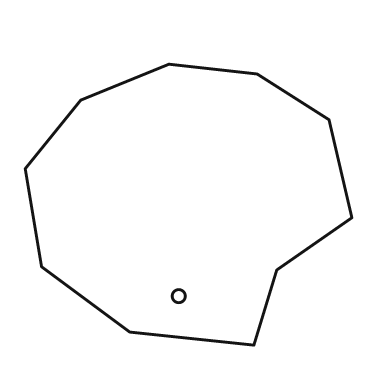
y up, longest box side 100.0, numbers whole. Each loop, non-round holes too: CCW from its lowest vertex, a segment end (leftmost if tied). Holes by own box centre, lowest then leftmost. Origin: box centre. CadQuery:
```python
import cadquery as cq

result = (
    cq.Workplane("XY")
    .moveTo(20.0, -43.0)
    .lineTo(27.0, -20.0)
    .lineTo(50.0, -4.0)
    .lineTo(43.0, 26.0)
    .lineTo(21.0, 40.0)
    .lineTo(-6.0, 43.0)
    .lineTo(-33.0, 32.0)
    .lineTo(-50.0, 11.0)
    .lineTo(-45.0, -19.0)
    .lineTo(-18.0, -39.0)
    .close()
    .moveTo(-3.0, -28.0)
    .circle(2.0)
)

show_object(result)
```